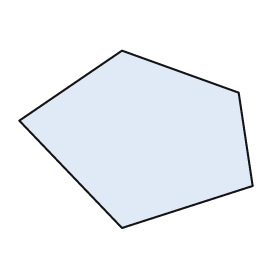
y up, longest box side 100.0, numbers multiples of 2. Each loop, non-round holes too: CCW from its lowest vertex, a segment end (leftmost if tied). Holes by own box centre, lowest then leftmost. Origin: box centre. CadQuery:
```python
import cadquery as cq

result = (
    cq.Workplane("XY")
    .moveTo(-6.0, -38.0)
    .lineTo(50.0, -20.0)
    .lineTo(44.0, 20.0)
    .lineTo(-6.0, 38.0)
    .lineTo(-50.0, 8.0)
    .close()
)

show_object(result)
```